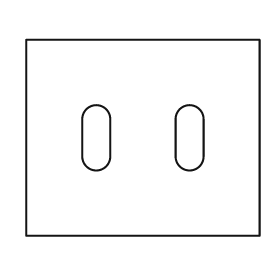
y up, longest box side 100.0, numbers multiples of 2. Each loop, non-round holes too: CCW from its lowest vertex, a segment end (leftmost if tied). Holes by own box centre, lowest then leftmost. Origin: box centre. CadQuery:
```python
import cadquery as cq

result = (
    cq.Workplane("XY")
    .moveTo(-50.0, -42.0)
    .lineTo(50.0, -42.0)
    .lineTo(50.0, 42.0)
    .lineTo(-50.0, 42.0)
    .close()
    .moveTo(-26.0, -8.0)
    .threePointArc((-20.0, -14.0), (-14.0, -8.0))
    .lineTo(-14.0, 8.0)
    .threePointArc((-20.0, 14.0), (-26.0, 8.0))
    .close()
    .moveTo(14.0, -8.0)
    .threePointArc((20.0, -14.0), (26.0, -8.0))
    .lineTo(26.0, 8.0)
    .threePointArc((20.0, 14.0), (14.0, 8.0))
    .close()
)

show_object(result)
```